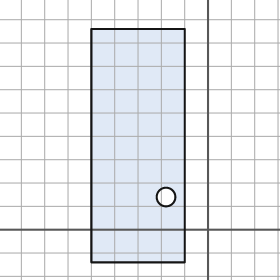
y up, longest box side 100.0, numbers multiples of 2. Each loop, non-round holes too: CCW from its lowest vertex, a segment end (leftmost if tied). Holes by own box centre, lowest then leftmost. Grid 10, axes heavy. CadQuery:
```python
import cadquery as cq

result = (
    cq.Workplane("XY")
    .moveTo(-50.0, -14.0)
    .lineTo(-10.0, -14.0)
    .lineTo(-10.0, 86.0)
    .lineTo(-50.0, 86.0)
    .close()
    .moveTo(-18.0, 14.0)
    .circle(4.0)
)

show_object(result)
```